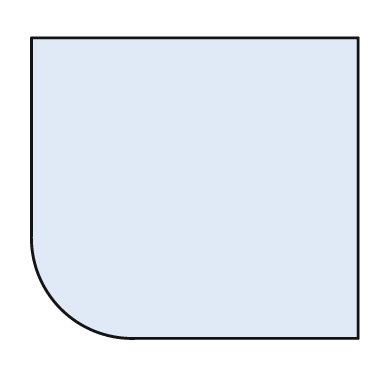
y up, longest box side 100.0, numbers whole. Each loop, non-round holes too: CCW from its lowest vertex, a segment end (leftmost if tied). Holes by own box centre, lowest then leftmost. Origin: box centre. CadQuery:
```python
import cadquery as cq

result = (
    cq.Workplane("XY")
    .moveTo(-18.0, -46.0)
    .lineTo(50.0, -46.0)
    .lineTo(50.0, 46.0)
    .lineTo(-50.0, 46.0)
    .lineTo(-50.0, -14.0)
    .threePointArc((-41.0, -37.0), (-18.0, -46.0))
    .close()
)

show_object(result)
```